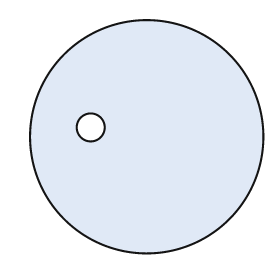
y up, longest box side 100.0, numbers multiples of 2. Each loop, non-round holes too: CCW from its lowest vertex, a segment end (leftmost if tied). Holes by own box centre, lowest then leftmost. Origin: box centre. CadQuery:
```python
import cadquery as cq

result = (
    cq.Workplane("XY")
    .moveTo(0.0, 0.0)
    .circle(50.0)
    .moveTo(-24.0, 4.0)
    .circle(6.0)
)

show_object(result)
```